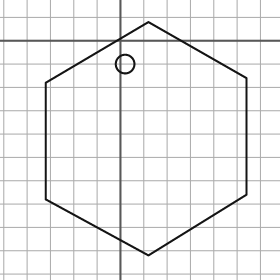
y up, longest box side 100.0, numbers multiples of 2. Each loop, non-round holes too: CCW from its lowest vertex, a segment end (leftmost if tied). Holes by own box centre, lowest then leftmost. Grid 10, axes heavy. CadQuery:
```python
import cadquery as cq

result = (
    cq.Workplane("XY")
    .moveTo(12.0, -92.0)
    .lineTo(54.0, -66.0)
    .lineTo(54.0, -16.0)
    .lineTo(12.0, 8.0)
    .lineTo(-32.0, -18.0)
    .lineTo(-32.0, -68.0)
    .close()
    .moveTo(2.0, -10.0)
    .circle(4.0)
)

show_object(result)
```